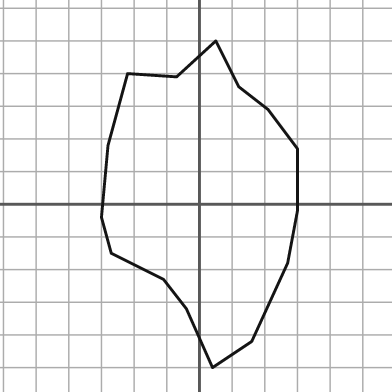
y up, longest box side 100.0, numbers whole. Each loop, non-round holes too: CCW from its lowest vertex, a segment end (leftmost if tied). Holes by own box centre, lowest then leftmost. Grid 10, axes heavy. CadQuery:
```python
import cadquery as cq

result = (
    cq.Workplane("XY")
    .moveTo(4.0, -50.0)
    .lineTo(16.0, -42.0)
    .lineTo(27.0, -18.0)
    .lineTo(30.0, -2.0)
    .lineTo(30.0, 17.0)
    .lineTo(21.0, 29.0)
    .lineTo(12.0, 36.0)
    .lineTo(5.0, 50.0)
    .lineTo(-7.0, 39.0)
    .lineTo(-22.0, 40.0)
    .lineTo(-28.0, 18.0)
    .lineTo(-30.0, -4.0)
    .lineTo(-27.0, -15.0)
    .lineTo(-11.0, -23.0)
    .lineTo(-4.0, -32.0)
    .close()
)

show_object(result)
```